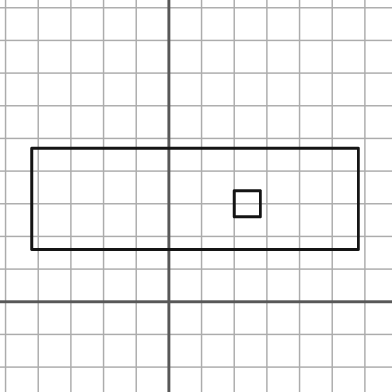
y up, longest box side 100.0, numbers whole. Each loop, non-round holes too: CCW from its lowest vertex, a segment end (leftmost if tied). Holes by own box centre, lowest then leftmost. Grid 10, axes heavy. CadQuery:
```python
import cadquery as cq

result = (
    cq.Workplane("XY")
    .moveTo(-42.0, 16.0)
    .lineTo(58.0, 16.0)
    .lineTo(58.0, 47.0)
    .lineTo(-42.0, 47.0)
    .close()
    .moveTo(20.0, 26.0)
    .lineTo(28.0, 26.0)
    .lineTo(28.0, 34.0)
    .lineTo(20.0, 34.0)
    .close()
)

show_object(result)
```